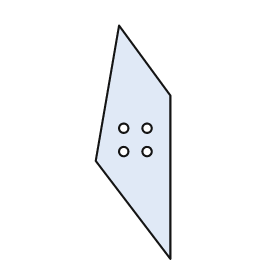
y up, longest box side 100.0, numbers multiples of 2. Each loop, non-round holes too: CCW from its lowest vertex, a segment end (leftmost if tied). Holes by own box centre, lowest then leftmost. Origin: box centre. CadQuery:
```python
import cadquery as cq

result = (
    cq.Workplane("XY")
    .moveTo(16.0, -50.0)
    .lineTo(16.0, 20.0)
    .lineTo(-6.0, 50.0)
    .lineTo(-16.0, -8.0)
    .close()
    .moveTo(-4.0, -4.0)
    .circle(2.0)
    .moveTo(6.0, -4.0)
    .circle(2.0)
    .moveTo(-4.0, 6.0)
    .circle(2.0)
    .moveTo(6.0, 6.0)
    .circle(2.0)
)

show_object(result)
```